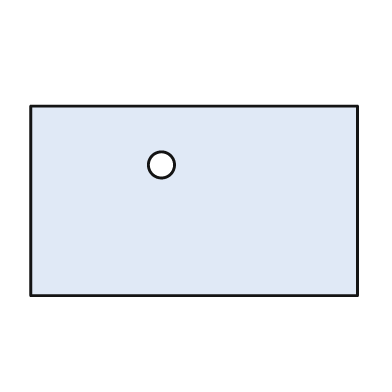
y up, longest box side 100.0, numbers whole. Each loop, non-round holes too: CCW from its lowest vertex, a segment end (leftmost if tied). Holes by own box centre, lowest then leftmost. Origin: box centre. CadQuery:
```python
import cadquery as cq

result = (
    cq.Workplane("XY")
    .moveTo(-50.0, -29.0)
    .lineTo(50.0, -29.0)
    .lineTo(50.0, 29.0)
    .lineTo(-50.0, 29.0)
    .close()
    .moveTo(-10.0, 11.0)
    .circle(4.0)
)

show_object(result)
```